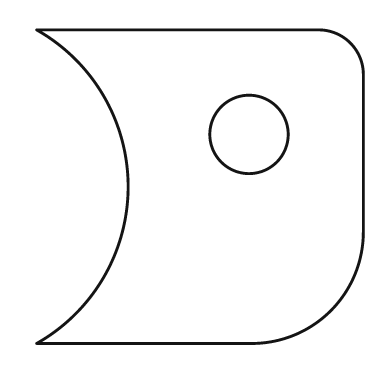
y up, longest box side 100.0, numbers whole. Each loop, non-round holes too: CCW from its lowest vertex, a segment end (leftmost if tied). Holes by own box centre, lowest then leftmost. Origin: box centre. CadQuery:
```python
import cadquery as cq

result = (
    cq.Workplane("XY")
    .moveTo(-50.0, -48.0)
    .lineTo(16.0, -48.0)
    .threePointArc((40.0, -38.0), (50.0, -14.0))
    .lineTo(50.0, 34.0)
    .threePointArc((46.0, 44.0), (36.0, 48.0))
    .lineTo(-50.0, 48.0)
    .threePointArc((-22.0, 0.0), (-50.0, -48.0))
    .close()
    .moveTo(15.0, 16.0)
    .circle(12.0)
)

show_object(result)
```